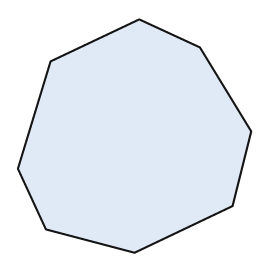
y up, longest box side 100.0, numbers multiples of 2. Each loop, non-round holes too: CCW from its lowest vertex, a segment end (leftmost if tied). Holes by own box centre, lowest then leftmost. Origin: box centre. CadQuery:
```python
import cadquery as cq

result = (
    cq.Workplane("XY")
    .moveTo(0.0, -50.0)
    .lineTo(42.0, -30.0)
    .lineTo(50.0, 2.0)
    .lineTo(28.0, 38.0)
    .lineTo(2.0, 50.0)
    .lineTo(-36.0, 32.0)
    .lineTo(-50.0, -14.0)
    .lineTo(-38.0, -40.0)
    .close()
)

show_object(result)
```